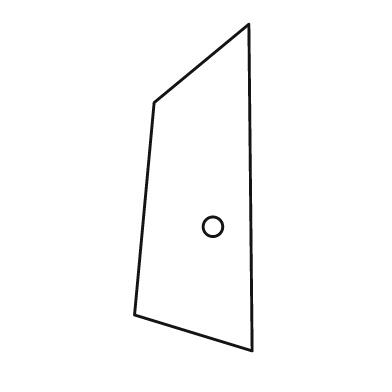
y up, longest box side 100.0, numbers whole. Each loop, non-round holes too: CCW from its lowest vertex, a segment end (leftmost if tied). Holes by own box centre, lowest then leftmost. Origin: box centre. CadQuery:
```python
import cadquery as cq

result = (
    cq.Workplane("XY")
    .moveTo(18.0, -50.0)
    .lineTo(17.0, 50.0)
    .lineTo(-12.0, 26.0)
    .lineTo(-18.0, -39.0)
    .close()
    .moveTo(6.0, -12.0)
    .circle(3.0)
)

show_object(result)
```